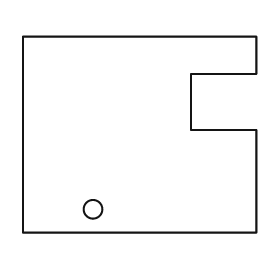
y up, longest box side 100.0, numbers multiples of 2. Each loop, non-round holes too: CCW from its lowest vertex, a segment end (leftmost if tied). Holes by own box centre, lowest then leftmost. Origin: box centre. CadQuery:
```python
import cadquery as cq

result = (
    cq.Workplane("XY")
    .moveTo(-50.0, -42.0)
    .lineTo(50.0, -42.0)
    .lineTo(50.0, 2.0)
    .lineTo(22.0, 2.0)
    .lineTo(22.0, 26.0)
    .lineTo(50.0, 26.0)
    .lineTo(50.0, 42.0)
    .lineTo(-50.0, 42.0)
    .close()
    .moveTo(-20.0, -32.0)
    .circle(4.0)
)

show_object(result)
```